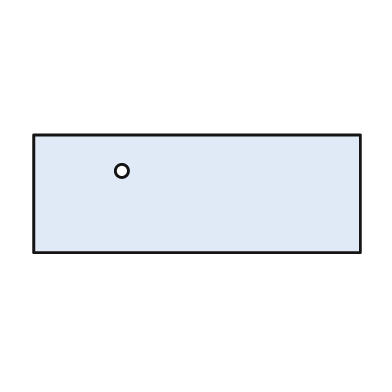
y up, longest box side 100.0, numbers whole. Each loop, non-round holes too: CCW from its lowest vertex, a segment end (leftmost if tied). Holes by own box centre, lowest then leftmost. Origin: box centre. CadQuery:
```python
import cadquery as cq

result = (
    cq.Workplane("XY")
    .moveTo(-50.0, -18.0)
    .lineTo(50.0, -18.0)
    .lineTo(50.0, 18.0)
    .lineTo(-50.0, 18.0)
    .close()
    .moveTo(-23.0, 7.0)
    .circle(2.0)
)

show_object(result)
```